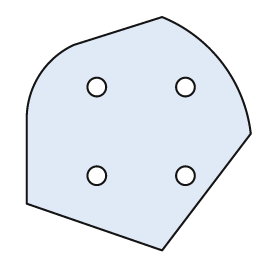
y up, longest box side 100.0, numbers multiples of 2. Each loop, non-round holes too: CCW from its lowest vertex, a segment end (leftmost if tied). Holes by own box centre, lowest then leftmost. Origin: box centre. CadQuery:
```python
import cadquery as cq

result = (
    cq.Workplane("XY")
    .moveTo(10.0, -50.0)
    .lineTo(48.0, 0.0)
    .threePointArc((36.0, 30.0), (10.0, 50.0))
    .lineTo(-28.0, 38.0)
    .threePointArc((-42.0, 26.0), (-48.0, 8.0))
    .lineTo(-48.0, -30.0)
    .close()
    .moveTo(-18.0, -18.0)
    .circle(4.0)
    .moveTo(20.0, -18.0)
    .circle(4.0)
    .moveTo(-18.0, 20.0)
    .circle(4.0)
    .moveTo(20.0, 20.0)
    .circle(4.0)
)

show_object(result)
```